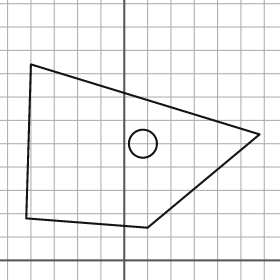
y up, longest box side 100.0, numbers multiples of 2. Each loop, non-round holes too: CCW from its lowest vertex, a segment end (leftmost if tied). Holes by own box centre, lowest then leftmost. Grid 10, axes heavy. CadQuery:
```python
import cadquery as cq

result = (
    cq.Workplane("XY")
    .moveTo(10.0, 14.0)
    .lineTo(58.0, 54.0)
    .lineTo(-40.0, 84.0)
    .lineTo(-42.0, 18.0)
    .close()
    .moveTo(8.0, 50.0)
    .circle(6.0)
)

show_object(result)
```